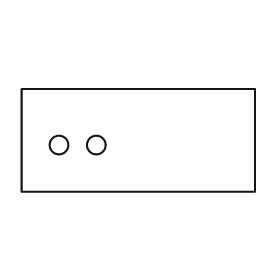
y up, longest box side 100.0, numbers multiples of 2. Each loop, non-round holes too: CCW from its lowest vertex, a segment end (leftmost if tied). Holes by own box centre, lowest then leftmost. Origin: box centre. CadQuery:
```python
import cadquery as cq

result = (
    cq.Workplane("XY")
    .moveTo(-50.0, -22.0)
    .lineTo(50.0, -22.0)
    .lineTo(50.0, 22.0)
    .lineTo(-50.0, 22.0)
    .close()
    .moveTo(-34.0, -2.0)
    .circle(4.0)
    .moveTo(-18.0, -2.0)
    .circle(4.0)
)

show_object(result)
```